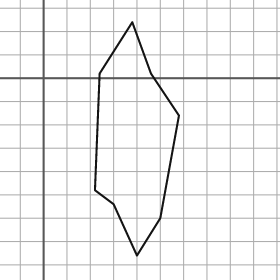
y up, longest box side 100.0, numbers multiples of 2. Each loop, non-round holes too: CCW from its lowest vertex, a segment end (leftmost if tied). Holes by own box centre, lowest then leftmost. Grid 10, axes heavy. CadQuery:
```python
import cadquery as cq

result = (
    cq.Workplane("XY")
    .moveTo(40.0, -76.0)
    .lineTo(50.0, -60.0)
    .lineTo(58.0, -16.0)
    .lineTo(46.0, 2.0)
    .lineTo(38.0, 24.0)
    .lineTo(24.0, 2.0)
    .lineTo(22.0, -48.0)
    .lineTo(30.0, -54.0)
    .close()
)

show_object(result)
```